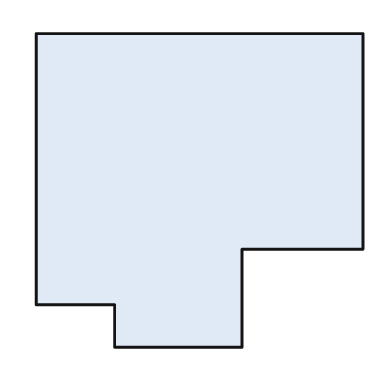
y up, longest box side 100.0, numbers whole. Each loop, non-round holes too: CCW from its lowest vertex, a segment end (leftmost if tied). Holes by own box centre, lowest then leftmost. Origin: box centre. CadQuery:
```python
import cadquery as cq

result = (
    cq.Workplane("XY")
    .moveTo(-26.0, -48.0)
    .lineTo(13.0, -48.0)
    .lineTo(13.0, -18.0)
    .lineTo(50.0, -18.0)
    .lineTo(50.0, 48.0)
    .lineTo(-50.0, 48.0)
    .lineTo(-50.0, -35.0)
    .lineTo(-26.0, -35.0)
    .close()
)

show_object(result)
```